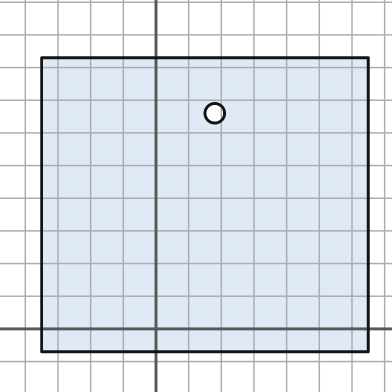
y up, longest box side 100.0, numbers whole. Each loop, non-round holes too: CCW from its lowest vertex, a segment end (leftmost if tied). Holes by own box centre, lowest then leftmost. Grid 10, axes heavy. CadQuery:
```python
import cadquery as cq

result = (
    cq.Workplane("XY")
    .moveTo(-35.0, -7.0)
    .lineTo(65.0, -7.0)
    .lineTo(65.0, 83.0)
    .lineTo(-35.0, 83.0)
    .close()
    .moveTo(18.0, 66.0)
    .circle(3.0)
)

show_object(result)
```